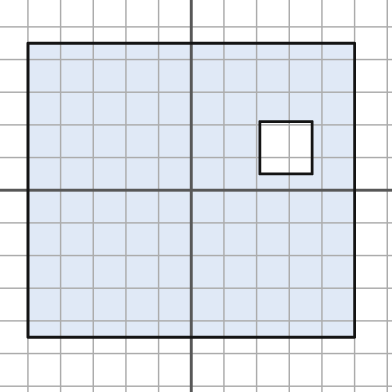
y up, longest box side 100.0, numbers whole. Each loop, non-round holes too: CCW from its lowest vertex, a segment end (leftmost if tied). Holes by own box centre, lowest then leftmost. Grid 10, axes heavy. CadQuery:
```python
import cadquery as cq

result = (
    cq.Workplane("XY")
    .moveTo(-50.0, -45.0)
    .lineTo(50.0, -45.0)
    .lineTo(50.0, 45.0)
    .lineTo(-50.0, 45.0)
    .close()
    .moveTo(21.0, 5.0)
    .lineTo(37.0, 5.0)
    .lineTo(37.0, 21.0)
    .lineTo(21.0, 21.0)
    .close()
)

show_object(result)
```